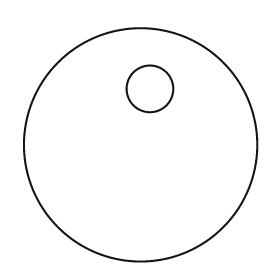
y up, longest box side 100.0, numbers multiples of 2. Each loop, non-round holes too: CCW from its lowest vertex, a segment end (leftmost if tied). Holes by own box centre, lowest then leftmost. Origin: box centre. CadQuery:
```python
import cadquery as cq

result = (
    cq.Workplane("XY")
    .moveTo(0.0, 0.0)
    .circle(50.0)
    .moveTo(4.0, 24.0)
    .circle(10.0)
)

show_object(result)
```